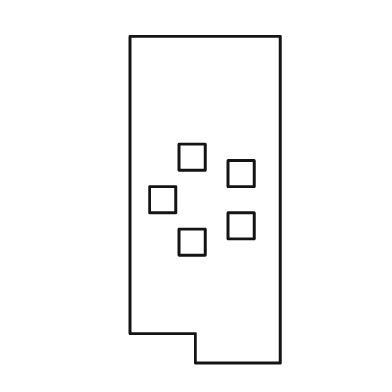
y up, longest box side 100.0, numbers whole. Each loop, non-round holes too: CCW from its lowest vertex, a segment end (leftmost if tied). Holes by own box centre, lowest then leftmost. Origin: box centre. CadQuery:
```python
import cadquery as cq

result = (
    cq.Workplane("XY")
    .moveTo(-3.0, -50.0)
    .lineTo(23.0, -50.0)
    .lineTo(23.0, 50.0)
    .lineTo(-23.0, 50.0)
    .lineTo(-23.0, -41.0)
    .lineTo(-3.0, -41.0)
    .close()
    .moveTo(-8.0, -17.0)
    .lineTo(0.0, -17.0)
    .lineTo(0.0, -9.0)
    .lineTo(-8.0, -9.0)
    .close()
    .moveTo(7.0, -12.0)
    .lineTo(15.0, -12.0)
    .lineTo(15.0, -4.0)
    .lineTo(7.0, -4.0)
    .close()
    .moveTo(-17.0, -4.0)
    .lineTo(-9.0, -4.0)
    .lineTo(-9.0, 4.0)
    .lineTo(-17.0, 4.0)
    .close()
    .moveTo(7.0, 4.0)
    .lineTo(15.0, 4.0)
    .lineTo(15.0, 12.0)
    .lineTo(7.0, 12.0)
    .close()
    .moveTo(-8.0, 9.0)
    .lineTo(0.0, 9.0)
    .lineTo(0.0, 17.0)
    .lineTo(-8.0, 17.0)
    .close()
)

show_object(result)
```